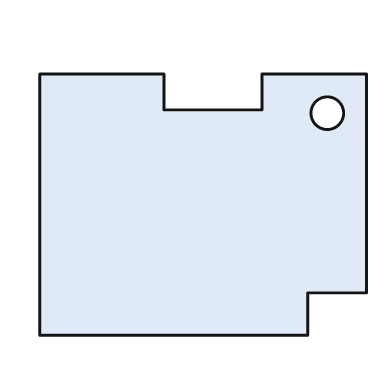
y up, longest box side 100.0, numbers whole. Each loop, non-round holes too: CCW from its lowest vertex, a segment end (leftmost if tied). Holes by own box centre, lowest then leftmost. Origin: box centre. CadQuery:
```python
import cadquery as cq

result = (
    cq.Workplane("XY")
    .moveTo(-50.0, -40.0)
    .lineTo(32.0, -40.0)
    .lineTo(32.0, -27.0)
    .lineTo(50.0, -27.0)
    .lineTo(50.0, 40.0)
    .lineTo(18.0, 40.0)
    .lineTo(18.0, 29.0)
    .lineTo(-12.0, 29.0)
    .lineTo(-12.0, 40.0)
    .lineTo(-50.0, 40.0)
    .close()
    .moveTo(38.0, 28.0)
    .circle(5.0)
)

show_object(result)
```